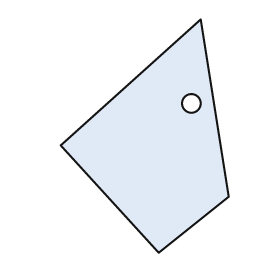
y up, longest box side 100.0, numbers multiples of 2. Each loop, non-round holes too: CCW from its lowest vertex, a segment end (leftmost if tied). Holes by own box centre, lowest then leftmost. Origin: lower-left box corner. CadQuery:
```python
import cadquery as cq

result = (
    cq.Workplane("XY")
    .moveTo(42.0, 0.0)
    .lineTo(72.0, 24.0)
    .lineTo(60.0, 100.0)
    .lineTo(0.0, 46.0)
    .close()
    .moveTo(56.0, 64.0)
    .circle(4.0)
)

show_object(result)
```